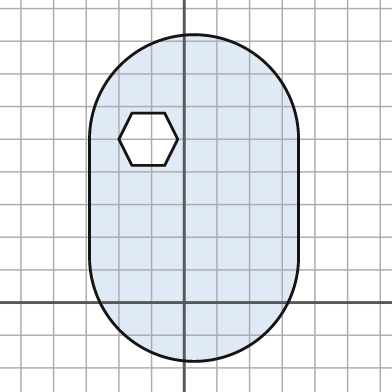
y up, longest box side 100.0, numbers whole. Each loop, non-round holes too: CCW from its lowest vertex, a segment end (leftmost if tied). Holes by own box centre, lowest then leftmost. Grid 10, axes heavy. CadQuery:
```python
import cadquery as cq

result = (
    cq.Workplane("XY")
    .moveTo(-29.0, 14.0)
    .threePointArc((3.0, -18.0), (35.0, 14.0))
    .lineTo(35.0, 50.0)
    .threePointArc((3.0, 82.0), (-29.0, 50.0))
    .close()
    .moveTo(-16.0, 42.0)
    .lineTo(-6.0, 42.0)
    .lineTo(-2.0, 50.0)
    .lineTo(-6.0, 58.0)
    .lineTo(-16.0, 58.0)
    .lineTo(-20.0, 50.0)
    .close()
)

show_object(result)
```